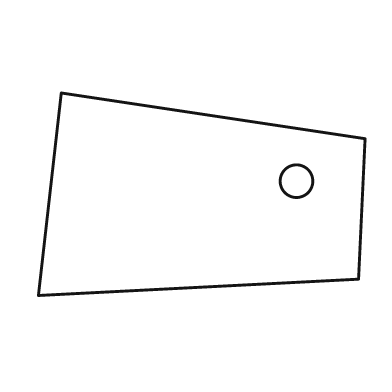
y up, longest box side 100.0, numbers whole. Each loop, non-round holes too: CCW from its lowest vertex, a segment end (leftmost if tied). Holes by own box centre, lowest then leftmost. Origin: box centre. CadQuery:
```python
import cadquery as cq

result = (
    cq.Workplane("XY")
    .moveTo(-50.0, -31.0)
    .lineTo(48.0, -26.0)
    .lineTo(50.0, 17.0)
    .lineTo(-43.0, 31.0)
    .close()
    .moveTo(29.0, 4.0)
    .circle(5.0)
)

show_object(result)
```